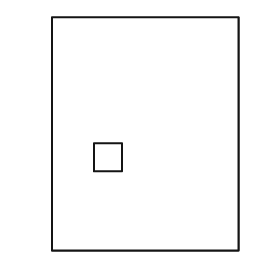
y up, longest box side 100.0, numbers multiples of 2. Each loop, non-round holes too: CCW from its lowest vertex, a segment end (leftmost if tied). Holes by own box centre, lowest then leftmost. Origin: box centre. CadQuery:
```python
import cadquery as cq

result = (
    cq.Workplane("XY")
    .moveTo(-40.0, -50.0)
    .lineTo(40.0, -50.0)
    .lineTo(40.0, 50.0)
    .lineTo(-40.0, 50.0)
    .close()
    .moveTo(-22.0, -16.0)
    .lineTo(-10.0, -16.0)
    .lineTo(-10.0, -4.0)
    .lineTo(-22.0, -4.0)
    .close()
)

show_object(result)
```